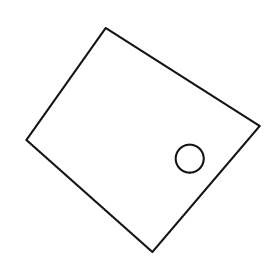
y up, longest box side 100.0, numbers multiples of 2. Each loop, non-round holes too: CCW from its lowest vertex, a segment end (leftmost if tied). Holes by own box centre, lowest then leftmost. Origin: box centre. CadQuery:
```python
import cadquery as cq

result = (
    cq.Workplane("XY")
    .moveTo(4.0, -48.0)
    .lineTo(50.0, 6.0)
    .lineTo(-16.0, 48.0)
    .lineTo(-50.0, 0.0)
    .close()
    .moveTo(20.0, -8.0)
    .circle(6.0)
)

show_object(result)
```